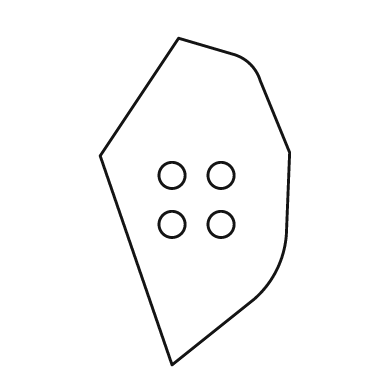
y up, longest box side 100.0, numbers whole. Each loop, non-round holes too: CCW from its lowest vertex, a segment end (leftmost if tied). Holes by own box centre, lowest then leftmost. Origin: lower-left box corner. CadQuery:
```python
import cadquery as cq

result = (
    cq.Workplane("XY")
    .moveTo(22.0, 0.0)
    .lineTo(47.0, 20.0)
    .threePointArc((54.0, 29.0), (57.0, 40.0))
    .lineTo(58.0, 65.0)
    .lineTo(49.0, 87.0)
    .threePointArc((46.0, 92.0), (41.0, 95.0))
    .lineTo(24.0, 100.0)
    .lineTo(0.0, 64.0)
    .close()
    .moveTo(22.0, 43.0)
    .circle(4.0)
    .moveTo(37.0, 43.0)
    .circle(4.0)
    .moveTo(22.0, 58.0)
    .circle(4.0)
    .moveTo(37.0, 58.0)
    .circle(4.0)
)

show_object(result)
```